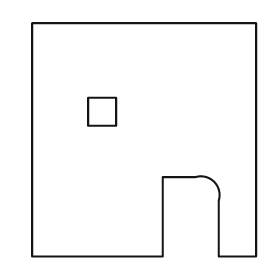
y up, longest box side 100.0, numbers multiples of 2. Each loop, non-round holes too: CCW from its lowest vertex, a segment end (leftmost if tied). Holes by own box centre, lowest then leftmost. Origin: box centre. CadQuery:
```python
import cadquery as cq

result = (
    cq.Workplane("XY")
    .moveTo(-48.0, -50.0)
    .lineTo(8.0, -50.0)
    .lineTo(8.0, -16.0)
    .lineTo(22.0, -16.0)
    .threePointArc((30.0, -18.0), (32.0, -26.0))
    .lineTo(32.0, -50.0)
    .lineTo(48.0, -50.0)
    .lineTo(48.0, 50.0)
    .lineTo(-48.0, 50.0)
    .close()
    .moveTo(-24.0, 6.0)
    .lineTo(-12.0, 6.0)
    .lineTo(-12.0, 18.0)
    .lineTo(-24.0, 18.0)
    .close()
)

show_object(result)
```